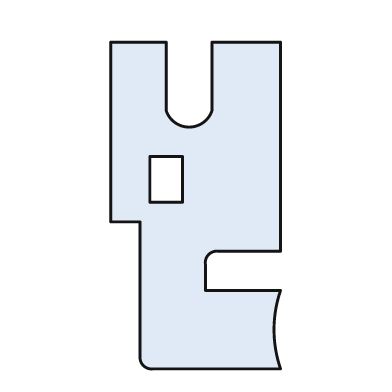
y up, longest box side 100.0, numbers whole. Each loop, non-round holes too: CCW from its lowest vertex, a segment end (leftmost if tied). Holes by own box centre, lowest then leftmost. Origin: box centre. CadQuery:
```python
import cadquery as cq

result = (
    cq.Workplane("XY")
    .moveTo(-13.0, -50.0)
    .lineTo(26.0, -50.0)
    .threePointArc((24.0, -38.0), (26.0, -26.0))
    .lineTo(3.0, -26.0)
    .lineTo(3.0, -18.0)
    .threePointArc((4.0, -15.0), (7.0, -14.0))
    .lineTo(26.0, -14.0)
    .lineTo(26.0, 50.0)
    .lineTo(5.0, 50.0)
    .lineTo(5.0, 29.0)
    .threePointArc((-2.0, 24.0), (-9.0, 29.0))
    .lineTo(-9.0, 50.0)
    .lineTo(-26.0, 50.0)
    .lineTo(-26.0, -5.0)
    .lineTo(-17.0, -5.0)
    .lineTo(-17.0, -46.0)
    .threePointArc((-16.0, -49.0), (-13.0, -50.0))
    .close()
    .moveTo(-14.0, 1.0)
    .lineTo(-4.0, 1.0)
    .lineTo(-4.0, 15.0)
    .lineTo(-14.0, 15.0)
    .close()
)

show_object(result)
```